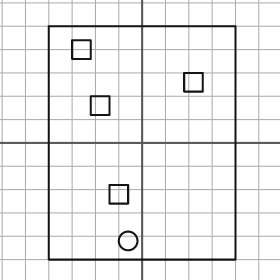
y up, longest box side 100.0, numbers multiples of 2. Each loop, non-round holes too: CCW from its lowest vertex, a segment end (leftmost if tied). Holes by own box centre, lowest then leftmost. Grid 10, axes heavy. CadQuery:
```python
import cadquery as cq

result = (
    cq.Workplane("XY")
    .moveTo(-40.0, -50.0)
    .lineTo(40.0, -50.0)
    .lineTo(40.0, 50.0)
    .lineTo(-40.0, 50.0)
    .close()
    .moveTo(-6.0, -42.0)
    .circle(4.0)
    .moveTo(-14.0, -26.0)
    .lineTo(-6.0, -26.0)
    .lineTo(-6.0, -18.0)
    .lineTo(-14.0, -18.0)
    .close()
    .moveTo(-22.0, 12.0)
    .lineTo(-14.0, 12.0)
    .lineTo(-14.0, 20.0)
    .lineTo(-22.0, 20.0)
    .close()
    .moveTo(18.0, 22.0)
    .lineTo(26.0, 22.0)
    .lineTo(26.0, 30.0)
    .lineTo(18.0, 30.0)
    .close()
    .moveTo(-30.0, 36.0)
    .lineTo(-22.0, 36.0)
    .lineTo(-22.0, 44.0)
    .lineTo(-30.0, 44.0)
    .close()
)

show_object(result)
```